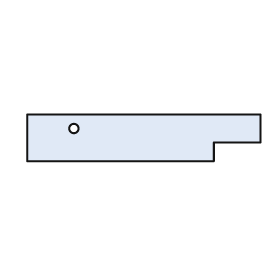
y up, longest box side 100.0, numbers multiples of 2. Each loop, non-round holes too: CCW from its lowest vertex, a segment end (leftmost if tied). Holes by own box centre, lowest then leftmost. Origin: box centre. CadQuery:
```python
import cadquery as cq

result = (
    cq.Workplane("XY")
    .moveTo(-50.0, -10.0)
    .lineTo(30.0, -10.0)
    .lineTo(30.0, -2.0)
    .lineTo(50.0, -2.0)
    .lineTo(50.0, 10.0)
    .lineTo(-50.0, 10.0)
    .close()
    .moveTo(-30.0, 4.0)
    .circle(2.0)
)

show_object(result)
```